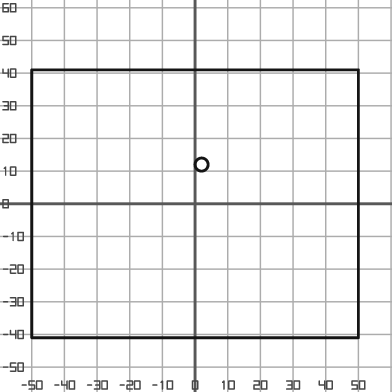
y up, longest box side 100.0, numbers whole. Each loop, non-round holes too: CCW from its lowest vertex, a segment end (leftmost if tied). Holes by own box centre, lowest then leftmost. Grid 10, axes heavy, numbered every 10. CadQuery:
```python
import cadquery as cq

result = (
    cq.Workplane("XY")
    .moveTo(-50.0, -41.0)
    .lineTo(50.0, -41.0)
    .lineTo(50.0, 41.0)
    .lineTo(-50.0, 41.0)
    .close()
    .moveTo(2.0, 12.0)
    .circle(2.0)
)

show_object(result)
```